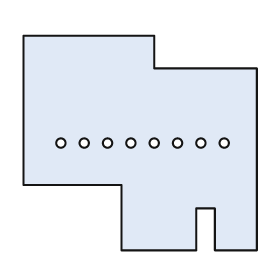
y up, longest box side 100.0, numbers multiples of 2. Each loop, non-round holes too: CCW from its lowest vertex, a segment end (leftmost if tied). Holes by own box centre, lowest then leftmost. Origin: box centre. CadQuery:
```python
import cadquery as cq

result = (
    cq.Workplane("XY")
    .moveTo(-8.0, -46.0)
    .lineTo(24.0, -46.0)
    .lineTo(24.0, -28.0)
    .lineTo(32.0, -28.0)
    .lineTo(32.0, -46.0)
    .lineTo(50.0, -46.0)
    .lineTo(50.0, 32.0)
    .lineTo(6.0, 32.0)
    .lineTo(6.0, 46.0)
    .lineTo(-50.0, 46.0)
    .lineTo(-50.0, -18.0)
    .lineTo(-8.0, -18.0)
    .close()
    .moveTo(-34.0, 0.0)
    .circle(2.0)
    .moveTo(-24.0, 0.0)
    .circle(2.0)
    .moveTo(-14.0, 0.0)
    .circle(2.0)
    .moveTo(-4.0, 0.0)
    .circle(2.0)
    .moveTo(6.0, 0.0)
    .circle(2.0)
    .moveTo(16.0, 0.0)
    .circle(2.0)
    .moveTo(26.0, 0.0)
    .circle(2.0)
    .moveTo(36.0, 0.0)
    .circle(2.0)
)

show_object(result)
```